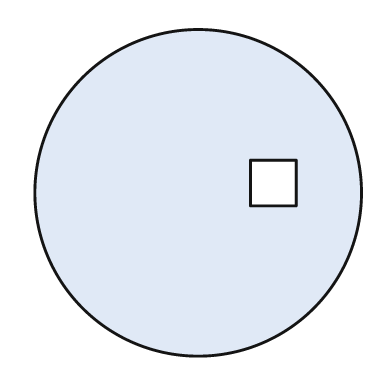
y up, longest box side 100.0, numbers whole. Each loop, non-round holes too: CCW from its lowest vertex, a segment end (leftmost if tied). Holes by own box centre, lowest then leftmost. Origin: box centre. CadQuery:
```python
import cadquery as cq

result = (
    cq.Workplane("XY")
    .moveTo(0.0, 0.0)
    .circle(50.0)
    .moveTo(16.0, -4.0)
    .lineTo(30.0, -4.0)
    .lineTo(30.0, 10.0)
    .lineTo(16.0, 10.0)
    .close()
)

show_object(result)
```